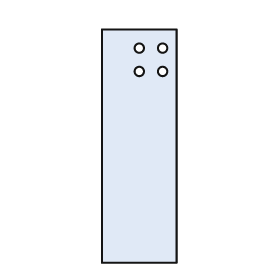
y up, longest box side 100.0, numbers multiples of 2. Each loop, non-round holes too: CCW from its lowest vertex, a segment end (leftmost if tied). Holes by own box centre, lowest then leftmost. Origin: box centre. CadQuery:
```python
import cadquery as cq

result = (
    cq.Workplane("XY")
    .moveTo(-16.0, -50.0)
    .lineTo(16.0, -50.0)
    .lineTo(16.0, 50.0)
    .lineTo(-16.0, 50.0)
    .close()
    .moveTo(0.0, 32.0)
    .circle(2.0)
    .moveTo(10.0, 32.0)
    .circle(2.0)
    .moveTo(0.0, 42.0)
    .circle(2.0)
    .moveTo(10.0, 42.0)
    .circle(2.0)
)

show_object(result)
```